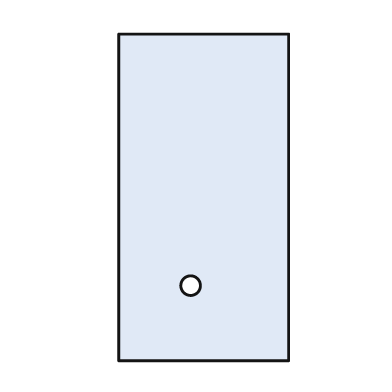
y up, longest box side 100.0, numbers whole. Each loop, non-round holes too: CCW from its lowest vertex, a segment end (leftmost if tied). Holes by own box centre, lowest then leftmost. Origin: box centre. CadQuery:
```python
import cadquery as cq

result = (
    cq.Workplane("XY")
    .moveTo(-26.0, -50.0)
    .lineTo(26.0, -50.0)
    .lineTo(26.0, 50.0)
    .lineTo(-26.0, 50.0)
    .close()
    .moveTo(-4.0, -27.0)
    .circle(3.0)
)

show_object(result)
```